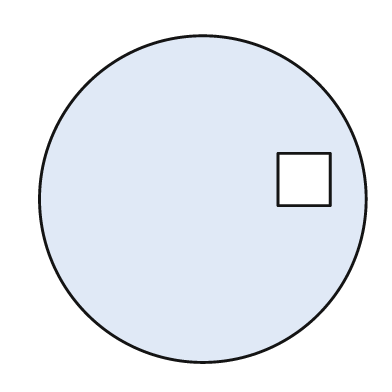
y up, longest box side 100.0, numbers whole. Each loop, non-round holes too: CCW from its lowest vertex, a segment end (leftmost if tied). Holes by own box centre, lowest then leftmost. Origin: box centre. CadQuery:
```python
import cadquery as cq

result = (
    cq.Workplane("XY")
    .moveTo(0.0, 0.0)
    .circle(50.0)
    .moveTo(23.0, -2.0)
    .lineTo(39.0, -2.0)
    .lineTo(39.0, 14.0)
    .lineTo(23.0, 14.0)
    .close()
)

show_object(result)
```